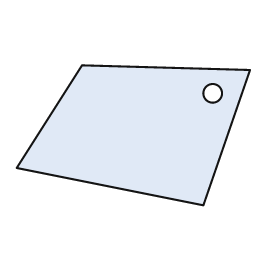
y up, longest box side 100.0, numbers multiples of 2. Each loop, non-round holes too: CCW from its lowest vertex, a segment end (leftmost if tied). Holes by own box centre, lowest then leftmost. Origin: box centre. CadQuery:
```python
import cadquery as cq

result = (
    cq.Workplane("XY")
    .moveTo(30.0, -30.0)
    .lineTo(50.0, 28.0)
    .lineTo(-22.0, 30.0)
    .lineTo(-50.0, -14.0)
    .close()
    .moveTo(34.0, 18.0)
    .circle(4.0)
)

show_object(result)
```